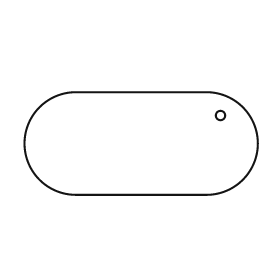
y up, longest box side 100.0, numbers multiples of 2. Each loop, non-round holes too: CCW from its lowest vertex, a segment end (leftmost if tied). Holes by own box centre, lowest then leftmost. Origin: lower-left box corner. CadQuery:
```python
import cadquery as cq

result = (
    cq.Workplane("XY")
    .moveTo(22.0, 0.0)
    .lineTo(78.0, 0.0)
    .threePointArc((100.0, 22.0), (78.0, 44.0))
    .lineTo(22.0, 44.0)
    .threePointArc((0.0, 22.0), (22.0, 0.0))
    .close()
    .moveTo(84.0, 34.0)
    .circle(2.0)
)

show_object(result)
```